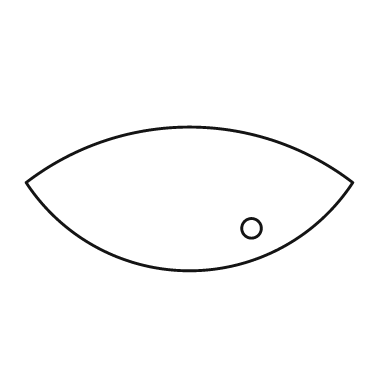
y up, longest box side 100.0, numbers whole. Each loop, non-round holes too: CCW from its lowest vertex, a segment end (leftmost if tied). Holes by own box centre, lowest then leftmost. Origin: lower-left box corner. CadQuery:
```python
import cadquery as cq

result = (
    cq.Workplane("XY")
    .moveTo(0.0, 27.0)
    .threePointArc((50.0, 0.0), (100.0, 27.0))
    .threePointArc((50.0, 44.0), (0.0, 27.0))
    .close()
    .moveTo(69.0, 13.0)
    .circle(3.0)
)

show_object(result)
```